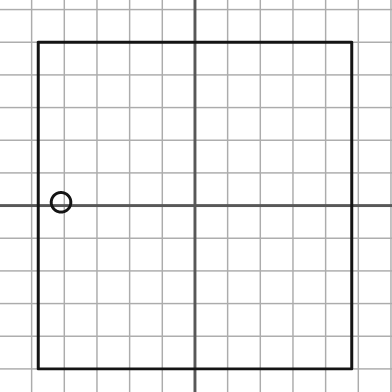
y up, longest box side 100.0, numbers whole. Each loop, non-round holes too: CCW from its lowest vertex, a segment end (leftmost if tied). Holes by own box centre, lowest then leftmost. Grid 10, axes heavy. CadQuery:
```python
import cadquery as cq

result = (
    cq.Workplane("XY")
    .moveTo(-48.0, -50.0)
    .lineTo(48.0, -50.0)
    .lineTo(48.0, 50.0)
    .lineTo(-48.0, 50.0)
    .close()
    .moveTo(-41.0, 1.0)
    .circle(3.0)
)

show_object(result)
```